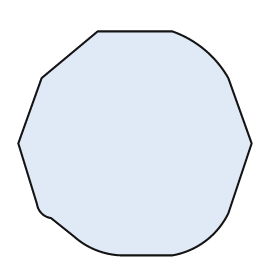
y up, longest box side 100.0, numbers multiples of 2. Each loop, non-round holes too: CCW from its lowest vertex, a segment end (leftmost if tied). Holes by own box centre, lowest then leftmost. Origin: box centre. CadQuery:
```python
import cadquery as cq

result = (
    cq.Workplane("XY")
    .moveTo(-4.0, -48.0)
    .lineTo(16.0, -48.0)
    .threePointArc((30.0, -42.0), (40.0, -30.0))
    .lineTo(50.0, 0.0)
    .lineTo(40.0, 28.0)
    .threePointArc((30.0, 40.0), (16.0, 48.0))
    .lineTo(-16.0, 48.0)
    .lineTo(-40.0, 28.0)
    .lineTo(-50.0, 0.0)
    .lineTo(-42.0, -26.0)
    .threePointArc((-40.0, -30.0), (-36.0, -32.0))
    .lineTo(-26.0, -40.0)
    .threePointArc((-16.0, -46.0), (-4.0, -48.0))
    .close()
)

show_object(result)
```